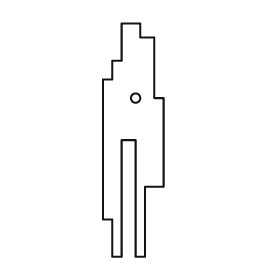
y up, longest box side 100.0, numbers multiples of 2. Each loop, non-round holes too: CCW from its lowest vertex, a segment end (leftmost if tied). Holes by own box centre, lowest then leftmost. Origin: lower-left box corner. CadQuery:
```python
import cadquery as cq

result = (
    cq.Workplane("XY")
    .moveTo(4.0, 0.0)
    .lineTo(8.0, 0.0)
    .lineTo(8.0, 50.0)
    .lineTo(14.0, 50.0)
    .lineTo(14.0, 0.0)
    .lineTo(18.0, 0.0)
    .lineTo(18.0, 30.0)
    .lineTo(26.0, 30.0)
    .lineTo(26.0, 68.0)
    .lineTo(22.0, 68.0)
    .lineTo(22.0, 94.0)
    .lineTo(16.0, 94.0)
    .lineTo(16.0, 100.0)
    .lineTo(8.0, 100.0)
    .lineTo(8.0, 84.0)
    .lineTo(4.0, 84.0)
    .lineTo(4.0, 76.0)
    .lineTo(0.0, 76.0)
    .lineTo(0.0, 16.0)
    .lineTo(4.0, 16.0)
    .close()
    .moveTo(14.0, 68.0)
    .circle(2.0)
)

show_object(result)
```